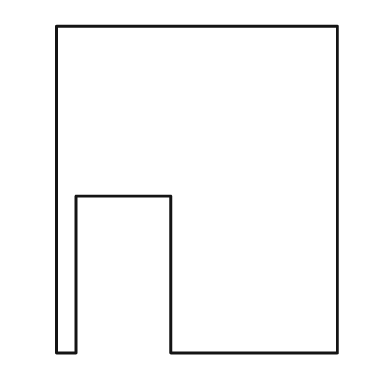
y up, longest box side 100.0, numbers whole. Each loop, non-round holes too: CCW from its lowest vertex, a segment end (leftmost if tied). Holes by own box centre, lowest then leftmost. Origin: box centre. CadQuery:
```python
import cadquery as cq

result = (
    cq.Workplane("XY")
    .moveTo(-43.0, -50.0)
    .lineTo(-37.0, -50.0)
    .lineTo(-37.0, -2.0)
    .lineTo(-8.0, -2.0)
    .lineTo(-8.0, -50.0)
    .lineTo(43.0, -50.0)
    .lineTo(43.0, 50.0)
    .lineTo(-43.0, 50.0)
    .close()
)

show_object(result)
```